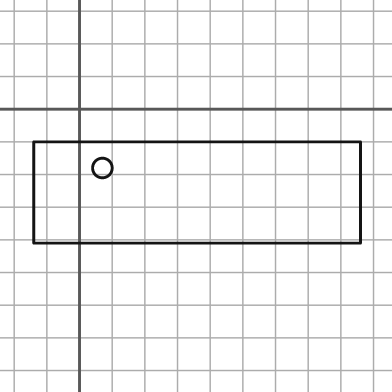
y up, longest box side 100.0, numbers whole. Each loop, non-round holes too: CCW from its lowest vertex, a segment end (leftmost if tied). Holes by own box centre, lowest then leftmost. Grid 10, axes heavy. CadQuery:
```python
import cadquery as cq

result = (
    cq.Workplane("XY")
    .moveTo(-14.0, -41.0)
    .lineTo(86.0, -41.0)
    .lineTo(86.0, -10.0)
    .lineTo(-14.0, -10.0)
    .close()
    .moveTo(7.0, -18.0)
    .circle(3.0)
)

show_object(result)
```